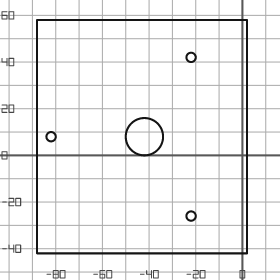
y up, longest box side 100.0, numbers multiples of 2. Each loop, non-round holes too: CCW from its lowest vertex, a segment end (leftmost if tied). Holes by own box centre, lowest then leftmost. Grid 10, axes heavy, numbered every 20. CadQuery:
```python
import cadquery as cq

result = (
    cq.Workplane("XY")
    .moveTo(-88.0, -42.0)
    .lineTo(2.0, -42.0)
    .lineTo(2.0, 58.0)
    .lineTo(-88.0, 58.0)
    .close()
    .moveTo(-22.0, -26.0)
    .circle(2.0)
    .moveTo(-82.0, 8.0)
    .circle(2.0)
    .moveTo(-42.0, 8.0)
    .circle(8.0)
    .moveTo(-22.0, 42.0)
    .circle(2.0)
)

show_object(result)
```